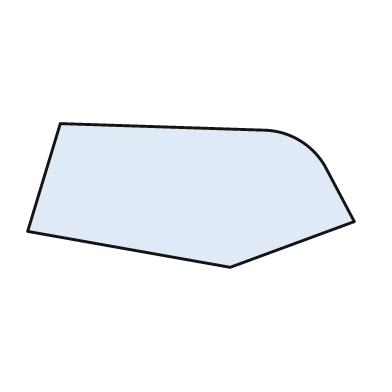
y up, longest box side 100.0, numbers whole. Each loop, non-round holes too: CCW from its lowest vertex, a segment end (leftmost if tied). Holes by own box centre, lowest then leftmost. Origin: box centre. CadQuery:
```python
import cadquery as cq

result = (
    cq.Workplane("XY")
    .moveTo(12.0, -22.0)
    .lineTo(50.0, -8.0)
    .lineTo(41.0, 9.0)
    .threePointArc((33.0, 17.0), (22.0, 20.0))
    .lineTo(-40.0, 22.0)
    .lineTo(-50.0, -11.0)
    .close()
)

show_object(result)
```